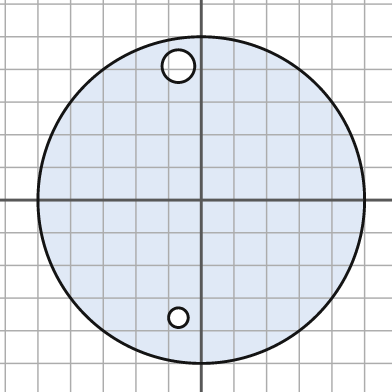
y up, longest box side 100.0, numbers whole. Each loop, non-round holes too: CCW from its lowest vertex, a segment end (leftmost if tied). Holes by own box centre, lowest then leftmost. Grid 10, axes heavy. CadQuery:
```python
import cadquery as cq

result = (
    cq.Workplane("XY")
    .moveTo(0.0, 0.0)
    .circle(50.0)
    .moveTo(-7.0, -36.0)
    .circle(3.0)
    .moveTo(-7.0, 41.0)
    .circle(5.0)
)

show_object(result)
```